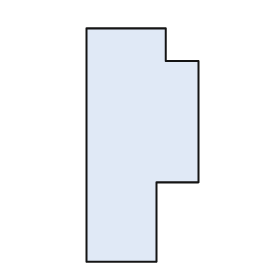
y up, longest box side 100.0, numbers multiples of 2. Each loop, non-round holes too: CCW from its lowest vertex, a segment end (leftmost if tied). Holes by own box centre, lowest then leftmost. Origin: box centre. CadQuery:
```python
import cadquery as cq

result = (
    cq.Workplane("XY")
    .moveTo(-24.0, -50.0)
    .lineTo(6.0, -50.0)
    .lineTo(6.0, -16.0)
    .lineTo(24.0, -16.0)
    .lineTo(24.0, 36.0)
    .lineTo(10.0, 36.0)
    .lineTo(10.0, 50.0)
    .lineTo(-24.0, 50.0)
    .close()
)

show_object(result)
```